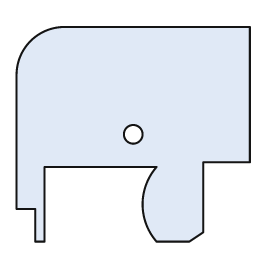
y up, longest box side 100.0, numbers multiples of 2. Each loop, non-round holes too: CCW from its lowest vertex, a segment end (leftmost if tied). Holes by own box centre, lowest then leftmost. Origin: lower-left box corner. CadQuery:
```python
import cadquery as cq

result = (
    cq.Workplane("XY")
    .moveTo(8.0, 0.0)
    .lineTo(12.0, 0.0)
    .lineTo(12.0, 32.0)
    .lineTo(60.0, 32.0)
    .threePointArc((54.0, 16.0), (60.0, 0.0))
    .lineTo(74.0, 0.0)
    .lineTo(80.0, 4.0)
    .lineTo(80.0, 34.0)
    .lineTo(100.0, 34.0)
    .lineTo(100.0, 92.0)
    .lineTo(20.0, 92.0)
    .threePointArc((6.0, 86.0), (0.0, 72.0))
    .lineTo(0.0, 14.0)
    .lineTo(8.0, 14.0)
    .close()
    .moveTo(50.0, 46.0)
    .circle(4.0)
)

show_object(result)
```